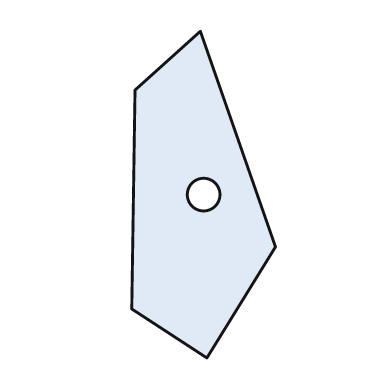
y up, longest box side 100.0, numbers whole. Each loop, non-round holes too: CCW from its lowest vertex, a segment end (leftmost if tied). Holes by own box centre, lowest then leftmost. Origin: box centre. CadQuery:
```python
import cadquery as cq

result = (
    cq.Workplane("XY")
    .moveTo(1.0, -50.0)
    .lineTo(22.0, -16.0)
    .lineTo(-1.0, 50.0)
    .lineTo(-21.0, 32.0)
    .lineTo(-22.0, -35.0)
    .close()
    .moveTo(0.0, 0.0)
    .circle(5.0)
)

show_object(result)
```